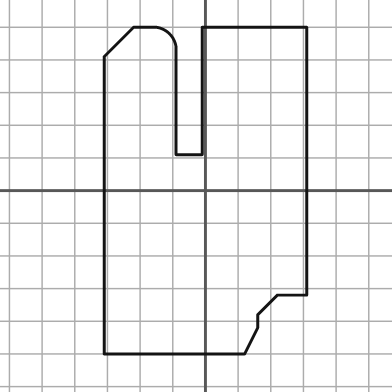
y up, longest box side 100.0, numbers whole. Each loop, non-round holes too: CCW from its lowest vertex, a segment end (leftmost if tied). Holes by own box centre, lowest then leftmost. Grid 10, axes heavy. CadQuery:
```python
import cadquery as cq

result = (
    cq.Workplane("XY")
    .moveTo(-31.0, -50.0)
    .lineTo(12.0, -50.0)
    .lineTo(16.0, -42.0)
    .lineTo(16.0, -38.0)
    .lineTo(22.0, -32.0)
    .lineTo(31.0, -32.0)
    .lineTo(31.0, 50.0)
    .lineTo(-1.0, 50.0)
    .lineTo(-1.0, 11.0)
    .lineTo(-9.0, 11.0)
    .lineTo(-9.0, 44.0)
    .threePointArc((-11.0, 48.0), (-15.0, 50.0))
    .lineTo(-22.0, 50.0)
    .lineTo(-31.0, 41.0)
    .close()
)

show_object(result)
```